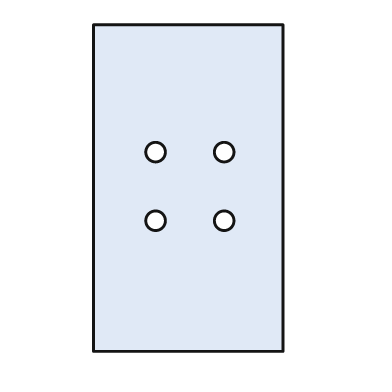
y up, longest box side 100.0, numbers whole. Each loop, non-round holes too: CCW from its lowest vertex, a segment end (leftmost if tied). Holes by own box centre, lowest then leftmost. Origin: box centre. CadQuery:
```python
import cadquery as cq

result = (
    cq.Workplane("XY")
    .moveTo(-29.0, -50.0)
    .lineTo(29.0, -50.0)
    .lineTo(29.0, 50.0)
    .lineTo(-29.0, 50.0)
    .close()
    .moveTo(-10.0, -10.0)
    .circle(3.0)
    .moveTo(11.0, -10.0)
    .circle(3.0)
    .moveTo(-10.0, 11.0)
    .circle(3.0)
    .moveTo(11.0, 11.0)
    .circle(3.0)
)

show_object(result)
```